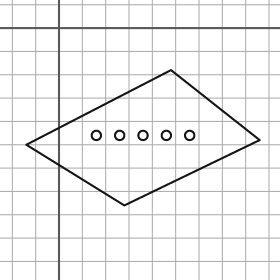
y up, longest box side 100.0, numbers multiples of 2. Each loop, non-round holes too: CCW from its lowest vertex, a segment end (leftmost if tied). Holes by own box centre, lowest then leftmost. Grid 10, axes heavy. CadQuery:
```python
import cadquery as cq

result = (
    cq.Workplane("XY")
    .moveTo(28.0, -76.0)
    .lineTo(86.0, -48.0)
    .lineTo(48.0, -18.0)
    .lineTo(-14.0, -50.0)
    .close()
    .moveTo(16.0, -46.0)
    .circle(2.0)
    .moveTo(26.0, -46.0)
    .circle(2.0)
    .moveTo(36.0, -46.0)
    .circle(2.0)
    .moveTo(46.0, -46.0)
    .circle(2.0)
    .moveTo(56.0, -46.0)
    .circle(2.0)
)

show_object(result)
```